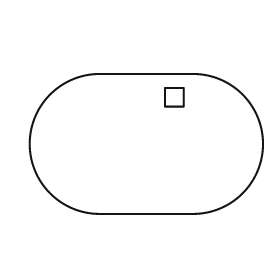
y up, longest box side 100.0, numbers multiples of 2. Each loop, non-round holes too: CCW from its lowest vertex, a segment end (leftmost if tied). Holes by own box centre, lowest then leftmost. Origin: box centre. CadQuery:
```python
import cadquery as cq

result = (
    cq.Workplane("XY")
    .moveTo(-20.0, -30.0)
    .lineTo(20.0, -30.0)
    .threePointArc((50.0, 0.0), (20.0, 30.0))
    .lineTo(-20.0, 30.0)
    .threePointArc((-50.0, 0.0), (-20.0, -30.0))
    .close()
    .moveTo(8.0, 16.0)
    .lineTo(16.0, 16.0)
    .lineTo(16.0, 24.0)
    .lineTo(8.0, 24.0)
    .close()
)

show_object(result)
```